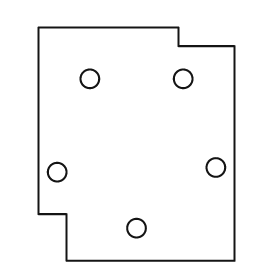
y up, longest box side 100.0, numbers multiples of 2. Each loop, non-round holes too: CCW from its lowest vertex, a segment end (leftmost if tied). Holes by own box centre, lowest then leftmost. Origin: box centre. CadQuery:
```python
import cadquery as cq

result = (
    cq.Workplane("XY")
    .moveTo(-30.0, -50.0)
    .lineTo(42.0, -50.0)
    .lineTo(42.0, 42.0)
    .lineTo(18.0, 42.0)
    .lineTo(18.0, 50.0)
    .lineTo(-42.0, 50.0)
    .lineTo(-42.0, -30.0)
    .lineTo(-30.0, -30.0)
    .close()
    .moveTo(0.0, -36.0)
    .circle(4.0)
    .moveTo(-34.0, -12.0)
    .circle(4.0)
    .moveTo(34.0, -10.0)
    .circle(4.0)
    .moveTo(-20.0, 28.0)
    .circle(4.0)
    .moveTo(20.0, 28.0)
    .circle(4.0)
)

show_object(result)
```